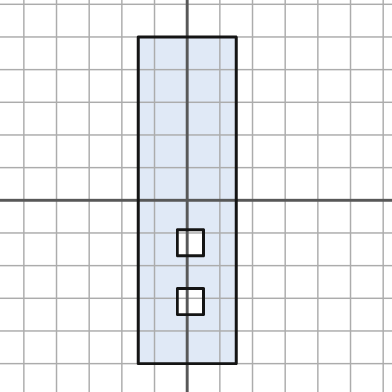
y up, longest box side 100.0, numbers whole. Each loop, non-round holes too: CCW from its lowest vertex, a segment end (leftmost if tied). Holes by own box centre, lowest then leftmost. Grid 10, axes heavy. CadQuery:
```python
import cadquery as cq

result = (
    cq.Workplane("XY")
    .moveTo(-15.0, -50.0)
    .lineTo(15.0, -50.0)
    .lineTo(15.0, 50.0)
    .lineTo(-15.0, 50.0)
    .close()
    .moveTo(-3.0, -35.0)
    .lineTo(5.0, -35.0)
    .lineTo(5.0, -27.0)
    .lineTo(-3.0, -27.0)
    .close()
    .moveTo(-3.0, -17.0)
    .lineTo(5.0, -17.0)
    .lineTo(5.0, -9.0)
    .lineTo(-3.0, -9.0)
    .close()
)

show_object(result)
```